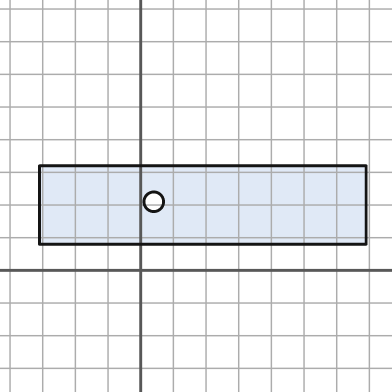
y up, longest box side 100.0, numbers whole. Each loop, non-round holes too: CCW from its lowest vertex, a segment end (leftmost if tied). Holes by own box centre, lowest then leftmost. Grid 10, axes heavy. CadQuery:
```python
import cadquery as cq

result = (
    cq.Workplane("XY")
    .moveTo(-31.0, 8.0)
    .lineTo(69.0, 8.0)
    .lineTo(69.0, 32.0)
    .lineTo(-31.0, 32.0)
    .close()
    .moveTo(4.0, 21.0)
    .circle(3.0)
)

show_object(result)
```